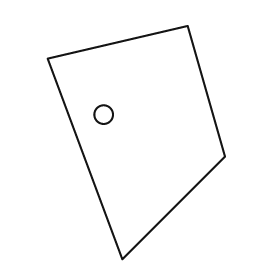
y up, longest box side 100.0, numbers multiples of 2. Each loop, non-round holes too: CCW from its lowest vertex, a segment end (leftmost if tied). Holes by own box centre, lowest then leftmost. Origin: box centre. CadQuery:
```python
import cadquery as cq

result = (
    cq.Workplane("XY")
    .moveTo(-6.0, -50.0)
    .lineTo(38.0, -6.0)
    .lineTo(22.0, 50.0)
    .lineTo(-38.0, 36.0)
    .close()
    .moveTo(-14.0, 12.0)
    .circle(4.0)
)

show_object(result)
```